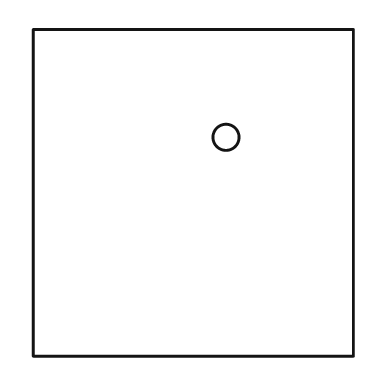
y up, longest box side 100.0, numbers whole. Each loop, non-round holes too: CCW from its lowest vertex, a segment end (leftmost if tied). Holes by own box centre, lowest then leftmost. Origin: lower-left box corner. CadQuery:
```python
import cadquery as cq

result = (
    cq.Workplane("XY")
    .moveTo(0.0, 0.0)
    .lineTo(98.0, 0.0)
    .lineTo(98.0, 100.0)
    .lineTo(0.0, 100.0)
    .close()
    .moveTo(59.0, 67.0)
    .circle(4.0)
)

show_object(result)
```